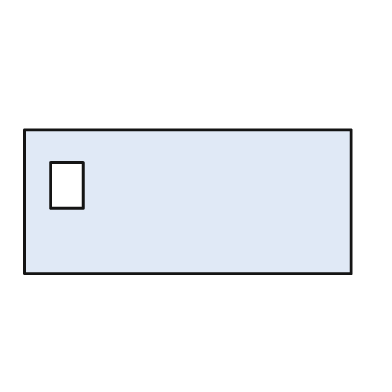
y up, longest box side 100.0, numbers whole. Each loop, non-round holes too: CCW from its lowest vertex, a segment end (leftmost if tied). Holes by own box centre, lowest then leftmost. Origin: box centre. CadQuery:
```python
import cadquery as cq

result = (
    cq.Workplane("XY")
    .moveTo(-50.0, -22.0)
    .lineTo(50.0, -22.0)
    .lineTo(50.0, 22.0)
    .lineTo(-50.0, 22.0)
    .close()
    .moveTo(-42.0, -2.0)
    .lineTo(-32.0, -2.0)
    .lineTo(-32.0, 12.0)
    .lineTo(-42.0, 12.0)
    .close()
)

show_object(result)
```